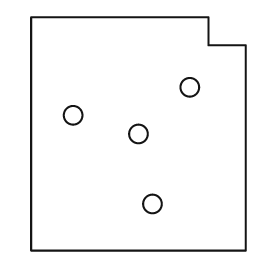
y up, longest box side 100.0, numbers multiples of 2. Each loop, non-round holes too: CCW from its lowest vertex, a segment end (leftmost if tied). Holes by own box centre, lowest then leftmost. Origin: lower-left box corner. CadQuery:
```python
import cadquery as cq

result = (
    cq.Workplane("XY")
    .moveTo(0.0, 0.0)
    .lineTo(92.0, 0.0)
    .lineTo(92.0, 88.0)
    .lineTo(76.0, 88.0)
    .lineTo(76.0, 100.0)
    .lineTo(0.0, 100.0)
    .close()
    .moveTo(52.0, 20.0)
    .circle(4.0)
    .moveTo(46.0, 50.0)
    .circle(4.0)
    .moveTo(18.0, 58.0)
    .circle(4.0)
    .moveTo(68.0, 70.0)
    .circle(4.0)
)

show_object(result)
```